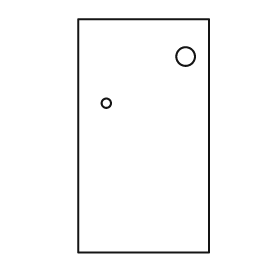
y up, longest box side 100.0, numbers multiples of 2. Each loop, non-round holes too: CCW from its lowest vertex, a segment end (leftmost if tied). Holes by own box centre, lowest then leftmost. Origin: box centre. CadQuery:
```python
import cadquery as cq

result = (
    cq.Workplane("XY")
    .moveTo(-28.0, -50.0)
    .lineTo(28.0, -50.0)
    .lineTo(28.0, 50.0)
    .lineTo(-28.0, 50.0)
    .close()
    .moveTo(-16.0, 14.0)
    .circle(2.0)
    .moveTo(18.0, 34.0)
    .circle(4.0)
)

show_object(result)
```